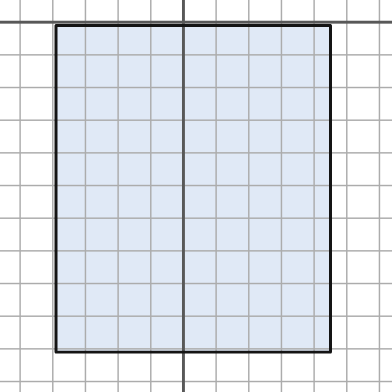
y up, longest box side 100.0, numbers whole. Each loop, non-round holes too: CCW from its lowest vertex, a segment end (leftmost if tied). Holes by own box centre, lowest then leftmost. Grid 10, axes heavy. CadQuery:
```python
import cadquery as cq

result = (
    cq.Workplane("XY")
    .moveTo(-39.0, -101.0)
    .lineTo(45.0, -101.0)
    .lineTo(45.0, -1.0)
    .lineTo(-39.0, -1.0)
    .close()
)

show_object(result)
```